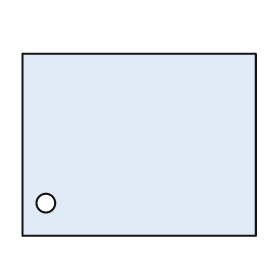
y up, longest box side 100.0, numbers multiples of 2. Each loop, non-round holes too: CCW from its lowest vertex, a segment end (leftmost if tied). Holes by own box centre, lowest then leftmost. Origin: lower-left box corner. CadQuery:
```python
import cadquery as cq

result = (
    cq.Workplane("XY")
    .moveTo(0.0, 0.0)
    .lineTo(100.0, 0.0)
    .lineTo(100.0, 78.0)
    .lineTo(0.0, 78.0)
    .close()
    .moveTo(10.0, 14.0)
    .circle(4.0)
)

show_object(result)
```